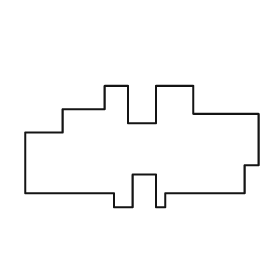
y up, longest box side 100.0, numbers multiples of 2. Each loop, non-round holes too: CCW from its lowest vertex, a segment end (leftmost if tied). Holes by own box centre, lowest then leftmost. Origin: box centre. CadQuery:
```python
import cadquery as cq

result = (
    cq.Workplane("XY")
    .moveTo(-12.0, -26.0)
    .lineTo(-4.0, -26.0)
    .lineTo(-4.0, -12.0)
    .lineTo(6.0, -12.0)
    .lineTo(6.0, -26.0)
    .lineTo(10.0, -26.0)
    .lineTo(10.0, -20.0)
    .lineTo(44.0, -20.0)
    .lineTo(44.0, -8.0)
    .lineTo(50.0, -8.0)
    .lineTo(50.0, 14.0)
    .lineTo(22.0, 14.0)
    .lineTo(22.0, 26.0)
    .lineTo(6.0, 26.0)
    .lineTo(6.0, 10.0)
    .lineTo(-6.0, 10.0)
    .lineTo(-6.0, 26.0)
    .lineTo(-16.0, 26.0)
    .lineTo(-16.0, 16.0)
    .lineTo(-34.0, 16.0)
    .lineTo(-34.0, 6.0)
    .lineTo(-50.0, 6.0)
    .lineTo(-50.0, -20.0)
    .lineTo(-12.0, -20.0)
    .close()
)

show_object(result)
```